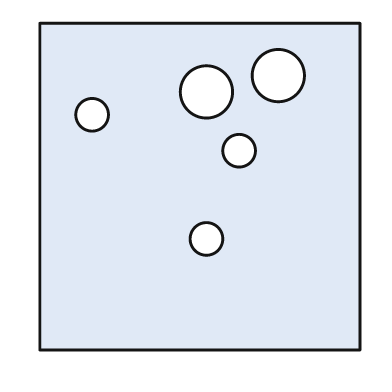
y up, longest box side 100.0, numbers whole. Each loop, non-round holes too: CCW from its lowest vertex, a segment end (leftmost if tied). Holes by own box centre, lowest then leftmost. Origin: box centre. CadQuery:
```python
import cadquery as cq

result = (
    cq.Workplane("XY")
    .moveTo(-49.0, -50.0)
    .lineTo(49.0, -50.0)
    .lineTo(49.0, 50.0)
    .lineTo(-49.0, 50.0)
    .close()
    .moveTo(2.0, -16.0)
    .circle(5.0)
    .moveTo(12.0, 11.0)
    .circle(5.0)
    .moveTo(-33.0, 22.0)
    .circle(5.0)
    .moveTo(2.0, 29.0)
    .circle(8.0)
    .moveTo(24.0, 34.0)
    .circle(8.0)
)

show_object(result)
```